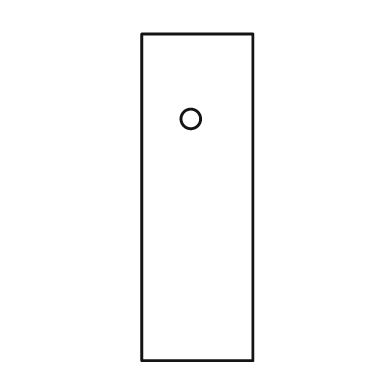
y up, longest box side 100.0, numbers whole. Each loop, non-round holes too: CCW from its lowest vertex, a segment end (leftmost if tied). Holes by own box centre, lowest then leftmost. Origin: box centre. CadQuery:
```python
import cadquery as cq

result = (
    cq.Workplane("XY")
    .moveTo(-17.0, -50.0)
    .lineTo(17.0, -50.0)
    .lineTo(17.0, 50.0)
    .lineTo(-17.0, 50.0)
    .close()
    .moveTo(-2.0, 24.0)
    .circle(3.0)
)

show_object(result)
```